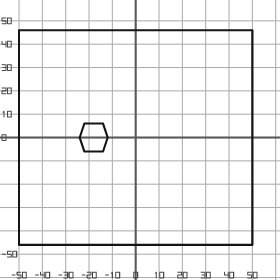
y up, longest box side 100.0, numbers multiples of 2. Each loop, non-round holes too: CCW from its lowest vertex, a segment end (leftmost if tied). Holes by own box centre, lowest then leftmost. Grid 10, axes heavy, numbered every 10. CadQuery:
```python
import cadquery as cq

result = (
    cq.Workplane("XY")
    .moveTo(-50.0, -46.0)
    .lineTo(50.0, -46.0)
    .lineTo(50.0, 46.0)
    .lineTo(-50.0, 46.0)
    .close()
    .moveTo(-22.0, -6.0)
    .lineTo(-14.0, -6.0)
    .lineTo(-12.0, 0.0)
    .lineTo(-14.0, 6.0)
    .lineTo(-22.0, 6.0)
    .lineTo(-24.0, 0.0)
    .close()
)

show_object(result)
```